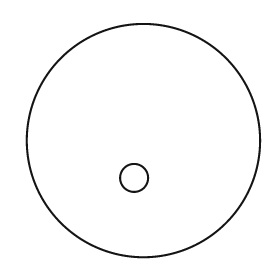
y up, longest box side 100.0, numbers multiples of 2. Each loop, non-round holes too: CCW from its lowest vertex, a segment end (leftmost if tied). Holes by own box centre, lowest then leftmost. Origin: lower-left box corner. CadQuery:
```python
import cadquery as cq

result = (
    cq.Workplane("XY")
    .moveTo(50.0, 50.0)
    .circle(50.0)
    .moveTo(46.0, 34.0)
    .circle(6.0)
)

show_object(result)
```